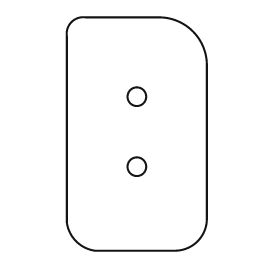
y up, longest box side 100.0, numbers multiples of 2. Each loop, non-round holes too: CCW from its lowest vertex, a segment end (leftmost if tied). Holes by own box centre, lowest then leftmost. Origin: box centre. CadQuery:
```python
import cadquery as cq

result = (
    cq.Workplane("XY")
    .moveTo(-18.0, -50.0)
    .lineTo(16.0, -50.0)
    .threePointArc((26.0, -46.0), (30.0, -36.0))
    .lineTo(30.0, 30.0)
    .threePointArc((24.0, 44.0), (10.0, 50.0))
    .lineTo(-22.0, 50.0)
    .threePointArc((-28.0, 48.0), (-30.0, 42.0))
    .lineTo(-30.0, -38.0)
    .threePointArc((-26.0, -46.0), (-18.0, -50.0))
    .close()
    .moveTo(0.0, -14.0)
    .circle(4.0)
    .moveTo(0.0, 16.0)
    .circle(4.0)
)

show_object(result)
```